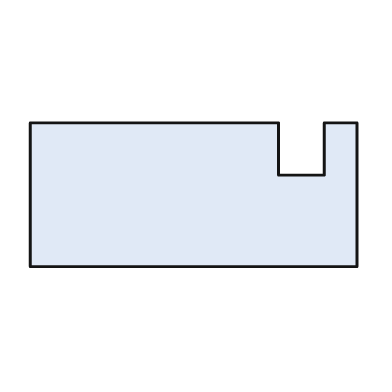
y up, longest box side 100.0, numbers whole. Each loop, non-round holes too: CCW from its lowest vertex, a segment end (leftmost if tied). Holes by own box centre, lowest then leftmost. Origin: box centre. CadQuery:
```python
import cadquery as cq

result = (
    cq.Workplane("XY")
    .moveTo(-50.0, -22.0)
    .lineTo(50.0, -22.0)
    .lineTo(50.0, 22.0)
    .lineTo(40.0, 22.0)
    .lineTo(40.0, 6.0)
    .lineTo(26.0, 6.0)
    .lineTo(26.0, 22.0)
    .lineTo(-50.0, 22.0)
    .close()
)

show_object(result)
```